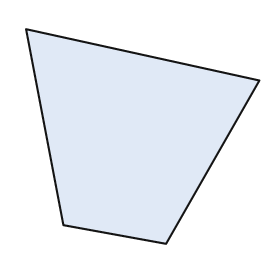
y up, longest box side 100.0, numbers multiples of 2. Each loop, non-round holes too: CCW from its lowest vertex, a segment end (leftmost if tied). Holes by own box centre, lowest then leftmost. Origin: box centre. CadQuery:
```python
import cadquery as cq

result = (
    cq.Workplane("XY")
    .moveTo(10.0, -46.0)
    .lineTo(50.0, 24.0)
    .lineTo(-50.0, 46.0)
    .lineTo(-34.0, -38.0)
    .close()
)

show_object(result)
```